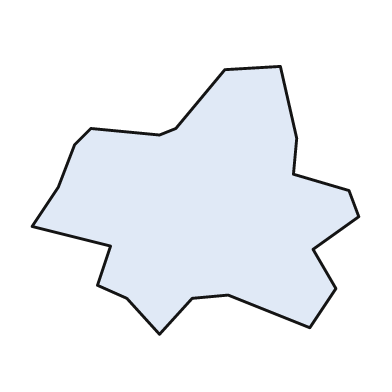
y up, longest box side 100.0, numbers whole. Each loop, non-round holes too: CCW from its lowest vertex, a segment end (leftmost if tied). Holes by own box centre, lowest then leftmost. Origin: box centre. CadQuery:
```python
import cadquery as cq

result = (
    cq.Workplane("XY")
    .moveTo(-11.0, -41.0)
    .lineTo(-1.0, -30.0)
    .lineTo(10.0, -29.0)
    .lineTo(35.0, -39.0)
    .lineTo(43.0, -27.0)
    .lineTo(36.0, -15.0)
    .lineTo(50.0, -5.0)
    .lineTo(47.0, 3.0)
    .lineTo(30.0, 8.0)
    .lineTo(31.0, 19.0)
    .lineTo(26.0, 41.0)
    .lineTo(9.0, 40.0)
    .lineTo(-6.0, 22.0)
    .lineTo(-11.0, 20.0)
    .lineTo(-32.0, 22.0)
    .lineTo(-37.0, 17.0)
    .lineTo(-42.0, 4.0)
    .lineTo(-50.0, -8.0)
    .lineTo(-26.0, -14.0)
    .lineTo(-30.0, -26.0)
    .lineTo(-21.0, -30.0)
    .close()
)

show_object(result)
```